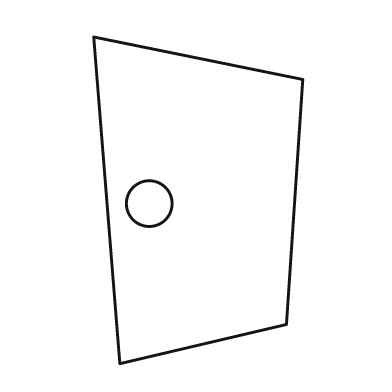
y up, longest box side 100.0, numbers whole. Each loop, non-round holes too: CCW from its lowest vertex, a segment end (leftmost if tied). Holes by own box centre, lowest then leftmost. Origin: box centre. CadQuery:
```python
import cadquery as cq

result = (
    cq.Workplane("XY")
    .moveTo(-24.0, -50.0)
    .lineTo(27.0, -38.0)
    .lineTo(32.0, 37.0)
    .lineTo(-32.0, 50.0)
    .close()
    .moveTo(-15.0, -1.0)
    .circle(7.0)
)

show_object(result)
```